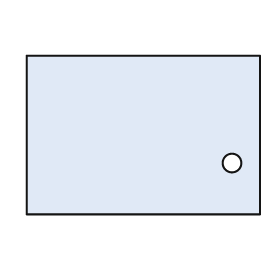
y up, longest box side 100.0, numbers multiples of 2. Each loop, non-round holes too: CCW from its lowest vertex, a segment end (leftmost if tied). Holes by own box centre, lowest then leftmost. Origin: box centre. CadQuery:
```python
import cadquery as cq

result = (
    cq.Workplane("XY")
    .moveTo(-50.0, -34.0)
    .lineTo(50.0, -34.0)
    .lineTo(50.0, 34.0)
    .lineTo(-50.0, 34.0)
    .close()
    .moveTo(38.0, -12.0)
    .circle(4.0)
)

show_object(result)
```